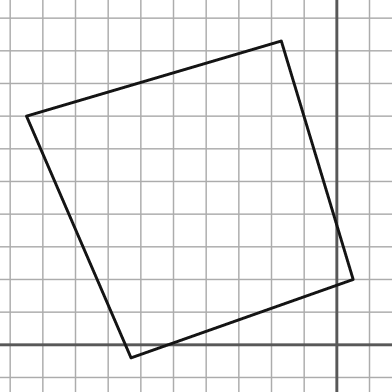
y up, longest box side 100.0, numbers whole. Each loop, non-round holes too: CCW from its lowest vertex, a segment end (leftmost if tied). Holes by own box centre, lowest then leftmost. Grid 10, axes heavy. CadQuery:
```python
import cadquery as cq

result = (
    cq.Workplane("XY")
    .moveTo(-63.0, -4.0)
    .lineTo(5.0, 20.0)
    .lineTo(-17.0, 93.0)
    .lineTo(-95.0, 70.0)
    .close()
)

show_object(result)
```